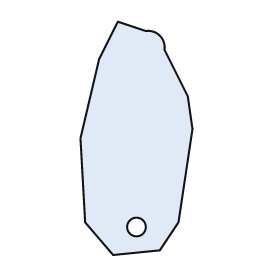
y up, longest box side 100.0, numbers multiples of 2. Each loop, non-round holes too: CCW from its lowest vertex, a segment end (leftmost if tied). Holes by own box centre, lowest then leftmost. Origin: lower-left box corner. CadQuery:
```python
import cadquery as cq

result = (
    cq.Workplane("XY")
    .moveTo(14.0, 0.0)
    .lineTo(34.0, 2.0)
    .lineTo(42.0, 14.0)
    .lineTo(48.0, 54.0)
    .lineTo(46.0, 68.0)
    .lineTo(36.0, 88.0)
    .threePointArc((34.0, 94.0), (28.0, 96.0))
    .lineTo(16.0, 100.0)
    .lineTo(8.0, 84.0)
    .lineTo(0.0, 50.0)
    .lineTo(2.0, 14.0)
    .close()
    .moveTo(24.0, 12.0)
    .circle(4.0)
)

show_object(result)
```